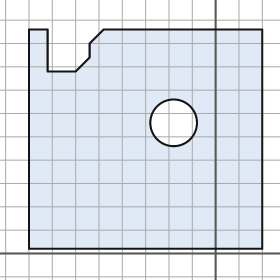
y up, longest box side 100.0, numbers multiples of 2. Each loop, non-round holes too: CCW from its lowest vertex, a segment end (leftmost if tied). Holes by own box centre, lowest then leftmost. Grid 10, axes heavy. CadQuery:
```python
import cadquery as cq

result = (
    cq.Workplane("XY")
    .moveTo(-80.0, 2.0)
    .lineTo(20.0, 2.0)
    .lineTo(20.0, 96.0)
    .lineTo(-48.0, 96.0)
    .lineTo(-54.0, 90.0)
    .lineTo(-54.0, 84.0)
    .lineTo(-60.0, 78.0)
    .lineTo(-72.0, 78.0)
    .lineTo(-72.0, 96.0)
    .lineTo(-80.0, 96.0)
    .close()
    .moveTo(-18.0, 56.0)
    .circle(10.0)
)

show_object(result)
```